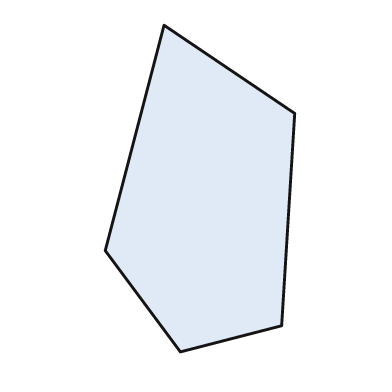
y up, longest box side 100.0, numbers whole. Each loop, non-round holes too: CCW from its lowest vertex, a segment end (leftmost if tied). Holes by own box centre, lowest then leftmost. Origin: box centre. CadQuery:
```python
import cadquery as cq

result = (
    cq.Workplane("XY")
    .moveTo(-6.0, -50.0)
    .lineTo(25.0, -42.0)
    .lineTo(29.0, 23.0)
    .lineTo(-11.0, 50.0)
    .lineTo(-29.0, -19.0)
    .close()
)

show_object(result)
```